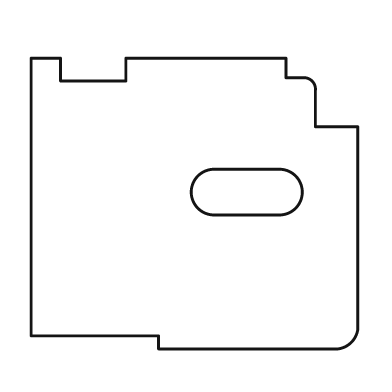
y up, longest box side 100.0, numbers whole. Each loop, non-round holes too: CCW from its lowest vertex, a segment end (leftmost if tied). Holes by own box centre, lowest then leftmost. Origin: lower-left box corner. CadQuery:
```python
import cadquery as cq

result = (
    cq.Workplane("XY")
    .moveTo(39.0, 0.0)
    .lineTo(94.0, 0.0)
    .threePointArc((98.0, 2.0), (100.0, 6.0))
    .lineTo(100.0, 68.0)
    .lineTo(87.0, 68.0)
    .lineTo(87.0, 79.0)
    .threePointArc((86.0, 82.0), (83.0, 83.0))
    .lineTo(78.0, 83.0)
    .lineTo(78.0, 89.0)
    .lineTo(29.0, 89.0)
    .lineTo(29.0, 82.0)
    .lineTo(9.0, 82.0)
    .lineTo(9.0, 89.0)
    .lineTo(0.0, 89.0)
    .lineTo(0.0, 4.0)
    .lineTo(39.0, 4.0)
    .close()
    .moveTo(56.0, 41.0)
    .lineTo(76.0, 41.0)
    .threePointArc((83.0, 48.0), (76.0, 55.0))
    .lineTo(56.0, 55.0)
    .threePointArc((49.0, 48.0), (56.0, 41.0))
    .close()
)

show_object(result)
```